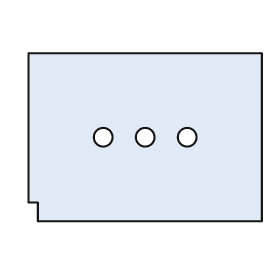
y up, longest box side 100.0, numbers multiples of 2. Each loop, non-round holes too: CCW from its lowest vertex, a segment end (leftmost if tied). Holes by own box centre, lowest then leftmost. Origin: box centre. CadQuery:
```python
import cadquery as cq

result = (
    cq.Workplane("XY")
    .moveTo(-46.0, -36.0)
    .lineTo(50.0, -36.0)
    .lineTo(50.0, 36.0)
    .lineTo(-50.0, 36.0)
    .lineTo(-50.0, -28.0)
    .lineTo(-46.0, -28.0)
    .close()
    .moveTo(-18.0, 0.0)
    .circle(4.0)
    .moveTo(0.0, 0.0)
    .circle(4.0)
    .moveTo(18.0, 0.0)
    .circle(4.0)
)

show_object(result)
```